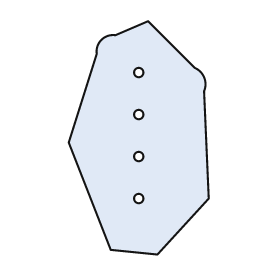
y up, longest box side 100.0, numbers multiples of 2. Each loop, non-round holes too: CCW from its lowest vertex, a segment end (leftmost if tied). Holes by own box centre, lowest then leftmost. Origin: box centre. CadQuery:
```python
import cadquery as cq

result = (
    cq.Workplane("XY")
    .moveTo(8.0, -50.0)
    .lineTo(30.0, -26.0)
    .lineTo(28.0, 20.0)
    .threePointArc((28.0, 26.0), (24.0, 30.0))
    .lineTo(4.0, 50.0)
    .lineTo(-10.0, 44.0)
    .threePointArc((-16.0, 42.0), (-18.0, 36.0))
    .lineTo(-30.0, -2.0)
    .lineTo(-12.0, -48.0)
    .close()
    .moveTo(0.0, -26.0)
    .circle(2.0)
    .moveTo(0.0, -8.0)
    .circle(2.0)
    .moveTo(0.0, 10.0)
    .circle(2.0)
    .moveTo(0.0, 28.0)
    .circle(2.0)
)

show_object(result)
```